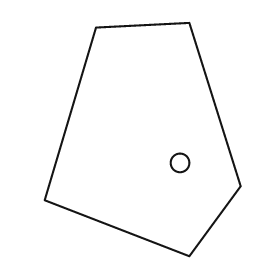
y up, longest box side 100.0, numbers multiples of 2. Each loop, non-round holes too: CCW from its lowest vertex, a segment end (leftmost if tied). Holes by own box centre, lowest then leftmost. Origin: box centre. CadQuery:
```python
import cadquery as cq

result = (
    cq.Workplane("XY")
    .moveTo(20.0, -50.0)
    .lineTo(42.0, -20.0)
    .lineTo(20.0, 50.0)
    .lineTo(-20.0, 48.0)
    .lineTo(-42.0, -26.0)
    .close()
    .moveTo(16.0, -10.0)
    .circle(4.0)
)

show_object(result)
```